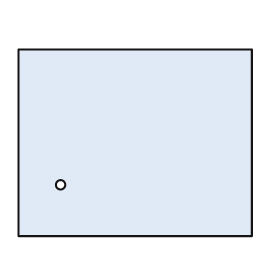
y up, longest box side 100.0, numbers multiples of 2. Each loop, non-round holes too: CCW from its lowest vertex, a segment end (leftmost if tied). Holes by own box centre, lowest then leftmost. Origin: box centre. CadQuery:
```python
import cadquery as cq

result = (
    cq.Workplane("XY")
    .moveTo(-50.0, -40.0)
    .lineTo(50.0, -40.0)
    .lineTo(50.0, 40.0)
    .lineTo(-50.0, 40.0)
    .close()
    .moveTo(-32.0, -18.0)
    .circle(2.0)
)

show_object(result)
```